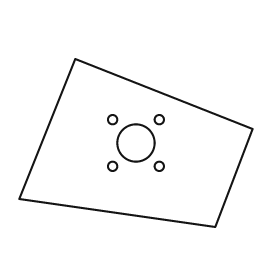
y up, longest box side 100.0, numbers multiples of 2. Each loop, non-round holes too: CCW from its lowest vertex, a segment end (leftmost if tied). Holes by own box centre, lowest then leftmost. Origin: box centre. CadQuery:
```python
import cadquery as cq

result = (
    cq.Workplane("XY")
    .moveTo(34.0, -36.0)
    .lineTo(50.0, 6.0)
    .lineTo(-26.0, 36.0)
    .lineTo(-50.0, -24.0)
    .close()
    .moveTo(-10.0, -10.0)
    .circle(2.0)
    .moveTo(10.0, -10.0)
    .circle(2.0)
    .moveTo(0.0, 0.0)
    .circle(8.0)
    .moveTo(-10.0, 10.0)
    .circle(2.0)
    .moveTo(10.0, 10.0)
    .circle(2.0)
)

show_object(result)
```